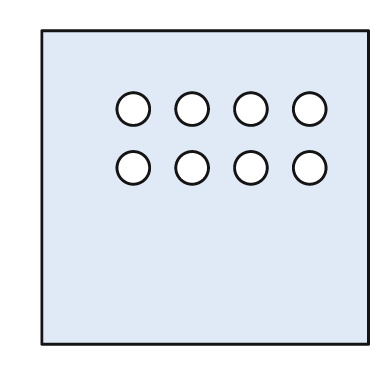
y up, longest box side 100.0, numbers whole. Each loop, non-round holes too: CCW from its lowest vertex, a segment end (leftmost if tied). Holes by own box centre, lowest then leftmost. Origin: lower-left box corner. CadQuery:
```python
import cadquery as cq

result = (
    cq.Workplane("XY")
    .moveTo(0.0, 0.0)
    .lineTo(100.0, 0.0)
    .lineTo(100.0, 96.0)
    .lineTo(0.0, 96.0)
    .close()
    .moveTo(28.0, 54.0)
    .circle(5.0)
    .moveTo(46.0, 54.0)
    .circle(5.0)
    .moveTo(64.0, 54.0)
    .circle(5.0)
    .moveTo(82.0, 54.0)
    .circle(5.0)
    .moveTo(28.0, 72.0)
    .circle(5.0)
    .moveTo(46.0, 72.0)
    .circle(5.0)
    .moveTo(64.0, 72.0)
    .circle(5.0)
    .moveTo(82.0, 72.0)
    .circle(5.0)
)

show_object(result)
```